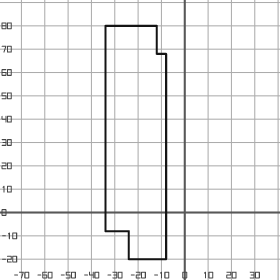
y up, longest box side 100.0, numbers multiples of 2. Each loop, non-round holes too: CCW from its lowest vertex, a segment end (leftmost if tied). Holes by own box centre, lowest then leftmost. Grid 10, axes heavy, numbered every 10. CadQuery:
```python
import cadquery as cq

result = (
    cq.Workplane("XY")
    .moveTo(-24.0, -20.0)
    .lineTo(-8.0, -20.0)
    .lineTo(-8.0, 68.0)
    .lineTo(-12.0, 68.0)
    .lineTo(-12.0, 80.0)
    .lineTo(-34.0, 80.0)
    .lineTo(-34.0, -8.0)
    .lineTo(-24.0, -8.0)
    .close()
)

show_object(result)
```